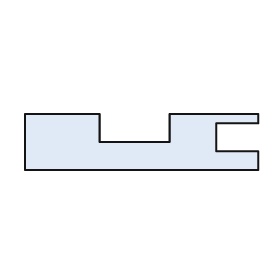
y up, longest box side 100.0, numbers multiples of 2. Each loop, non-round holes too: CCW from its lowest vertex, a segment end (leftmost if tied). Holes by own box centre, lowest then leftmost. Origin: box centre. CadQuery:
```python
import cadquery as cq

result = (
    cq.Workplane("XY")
    .moveTo(-50.0, -12.0)
    .lineTo(50.0, -12.0)
    .lineTo(50.0, -4.0)
    .lineTo(32.0, -4.0)
    .lineTo(32.0, 8.0)
    .lineTo(50.0, 8.0)
    .lineTo(50.0, 12.0)
    .lineTo(12.0, 12.0)
    .lineTo(12.0, 0.0)
    .lineTo(-18.0, 0.0)
    .lineTo(-18.0, 12.0)
    .lineTo(-50.0, 12.0)
    .close()
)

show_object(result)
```